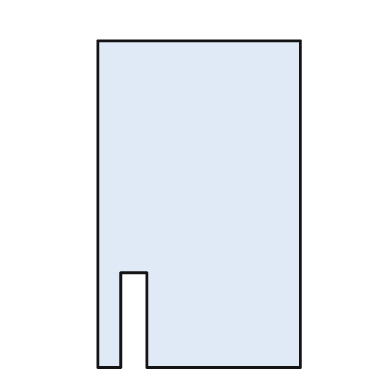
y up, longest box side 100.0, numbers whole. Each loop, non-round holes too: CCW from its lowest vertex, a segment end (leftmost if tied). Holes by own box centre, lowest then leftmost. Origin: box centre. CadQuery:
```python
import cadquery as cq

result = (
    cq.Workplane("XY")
    .moveTo(-31.0, -50.0)
    .lineTo(-24.0, -50.0)
    .lineTo(-24.0, -21.0)
    .lineTo(-16.0, -21.0)
    .lineTo(-16.0, -50.0)
    .lineTo(31.0, -50.0)
    .lineTo(31.0, 50.0)
    .lineTo(-31.0, 50.0)
    .close()
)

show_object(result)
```